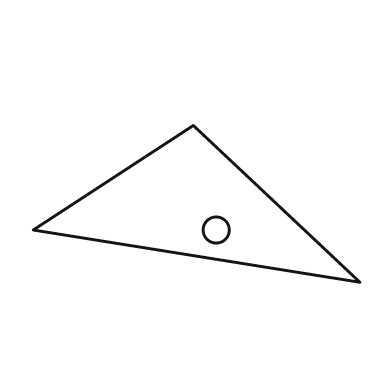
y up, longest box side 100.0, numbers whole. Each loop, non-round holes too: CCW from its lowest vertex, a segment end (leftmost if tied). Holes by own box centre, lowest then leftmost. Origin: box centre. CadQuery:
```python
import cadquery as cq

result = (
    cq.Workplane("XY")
    .moveTo(50.0, -24.0)
    .lineTo(-1.0, 24.0)
    .lineTo(-50.0, -8.0)
    .close()
    .moveTo(6.0, -8.0)
    .circle(4.0)
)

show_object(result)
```